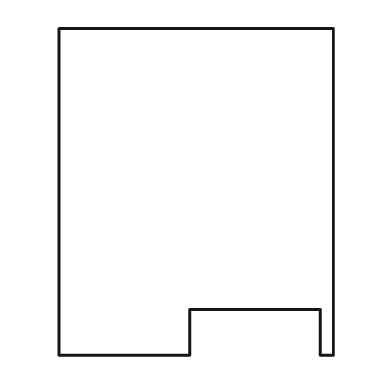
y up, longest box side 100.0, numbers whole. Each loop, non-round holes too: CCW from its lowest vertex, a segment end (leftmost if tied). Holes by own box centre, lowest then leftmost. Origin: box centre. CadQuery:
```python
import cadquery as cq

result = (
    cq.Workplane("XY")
    .moveTo(-42.0, -50.0)
    .lineTo(-2.0, -50.0)
    .lineTo(-2.0, -36.0)
    .lineTo(38.0, -36.0)
    .lineTo(38.0, -50.0)
    .lineTo(42.0, -50.0)
    .lineTo(42.0, 50.0)
    .lineTo(-42.0, 50.0)
    .close()
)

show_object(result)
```